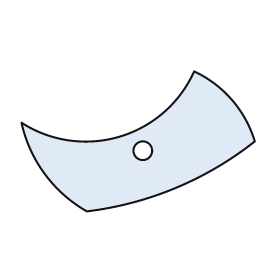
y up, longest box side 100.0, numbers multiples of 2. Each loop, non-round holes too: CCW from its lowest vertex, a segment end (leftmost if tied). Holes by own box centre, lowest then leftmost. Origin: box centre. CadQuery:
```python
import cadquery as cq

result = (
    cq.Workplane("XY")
    .moveTo(-22.0, -30.0)
    .threePointArc((16.0, -20.0), (50.0, 0.0))
    .threePointArc((40.0, 18.0), (24.0, 30.0))
    .threePointArc((-8.0, 2.0), (-50.0, 8.0))
    .threePointArc((-40.0, -14.0), (-22.0, -30.0))
    .close()
    .moveTo(2.0, -4.0)
    .circle(4.0)
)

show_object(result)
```